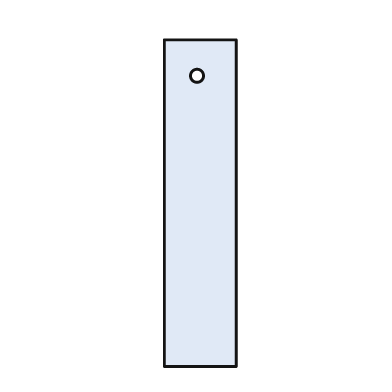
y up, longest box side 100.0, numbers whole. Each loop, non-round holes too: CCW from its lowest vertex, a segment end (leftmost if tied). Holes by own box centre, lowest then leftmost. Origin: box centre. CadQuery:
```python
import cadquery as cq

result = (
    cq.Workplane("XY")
    .moveTo(-11.0, -50.0)
    .lineTo(11.0, -50.0)
    .lineTo(11.0, 50.0)
    .lineTo(-11.0, 50.0)
    .close()
    .moveTo(-1.0, 39.0)
    .circle(2.0)
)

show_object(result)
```